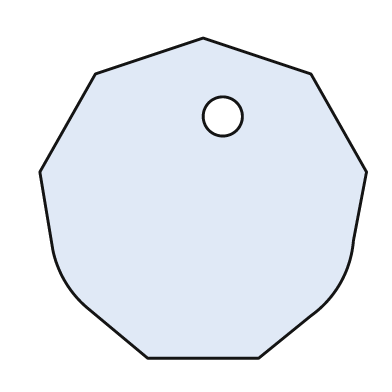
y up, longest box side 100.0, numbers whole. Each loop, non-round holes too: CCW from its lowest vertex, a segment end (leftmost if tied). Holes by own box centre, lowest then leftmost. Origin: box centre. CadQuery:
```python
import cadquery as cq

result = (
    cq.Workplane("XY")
    .moveTo(-17.0, -49.0)
    .lineTo(17.0, -49.0)
    .lineTo(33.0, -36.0)
    .threePointArc((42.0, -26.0), (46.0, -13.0))
    .lineTo(50.0, 8.0)
    .lineTo(33.0, 38.0)
    .lineTo(0.0, 49.0)
    .lineTo(-33.0, 38.0)
    .lineTo(-50.0, 8.0)
    .lineTo(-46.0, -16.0)
    .threePointArc((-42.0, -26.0), (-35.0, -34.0))
    .close()
    .moveTo(6.0, 25.0)
    .circle(6.0)
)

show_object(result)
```